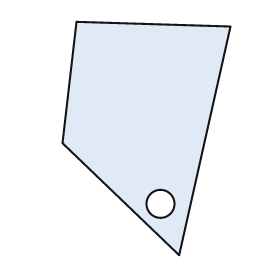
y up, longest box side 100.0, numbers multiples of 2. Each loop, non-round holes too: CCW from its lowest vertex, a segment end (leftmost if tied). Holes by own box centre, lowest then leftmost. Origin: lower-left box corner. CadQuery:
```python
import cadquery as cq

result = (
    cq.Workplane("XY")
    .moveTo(50.0, 0.0)
    .lineTo(72.0, 98.0)
    .lineTo(6.0, 100.0)
    .lineTo(0.0, 48.0)
    .close()
    .moveTo(42.0, 22.0)
    .circle(6.0)
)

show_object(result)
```